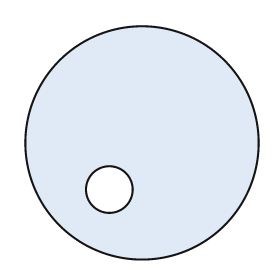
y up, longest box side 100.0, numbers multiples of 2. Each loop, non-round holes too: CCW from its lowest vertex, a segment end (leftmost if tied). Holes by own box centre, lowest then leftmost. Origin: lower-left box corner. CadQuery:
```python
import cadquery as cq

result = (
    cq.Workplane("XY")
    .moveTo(50.0, 50.0)
    .circle(50.0)
    .moveTo(36.0, 30.0)
    .circle(10.0)
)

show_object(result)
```